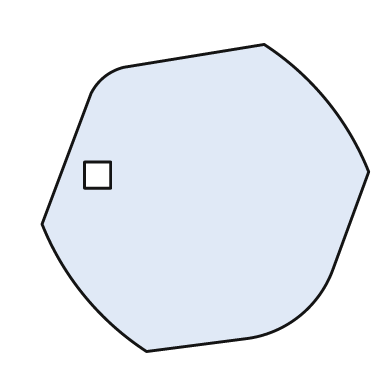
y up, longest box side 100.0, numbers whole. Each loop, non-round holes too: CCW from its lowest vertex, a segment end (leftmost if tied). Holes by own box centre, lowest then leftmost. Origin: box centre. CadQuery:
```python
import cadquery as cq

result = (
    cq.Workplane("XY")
    .moveTo(-18.0, -47.0)
    .lineTo(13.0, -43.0)
    .threePointArc((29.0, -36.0), (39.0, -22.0))
    .lineTo(50.0, 8.0)
    .threePointArc((37.0, 30.0), (18.0, 47.0))
    .lineTo(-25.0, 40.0)
    .threePointArc((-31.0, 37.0), (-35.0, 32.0))
    .lineTo(-50.0, -8.0)
    .threePointArc((-37.0, -30.0), (-18.0, -47.0))
    .close()
    .moveTo(-37.0, 3.0)
    .lineTo(-29.0, 3.0)
    .lineTo(-29.0, 11.0)
    .lineTo(-37.0, 11.0)
    .close()
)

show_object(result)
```